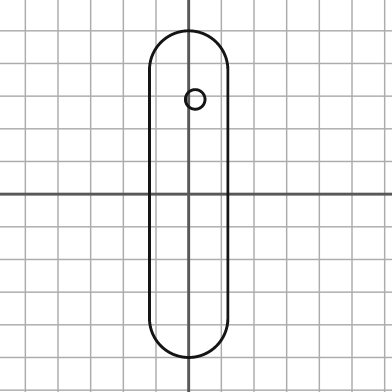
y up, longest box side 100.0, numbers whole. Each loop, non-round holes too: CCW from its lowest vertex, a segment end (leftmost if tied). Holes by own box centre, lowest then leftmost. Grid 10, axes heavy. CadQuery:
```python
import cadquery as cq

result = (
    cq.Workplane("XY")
    .moveTo(-12.0, -38.0)
    .threePointArc((0.0, -50.0), (12.0, -38.0))
    .lineTo(12.0, 38.0)
    .threePointArc((0.0, 50.0), (-12.0, 38.0))
    .close()
    .moveTo(2.0, 29.0)
    .circle(3.0)
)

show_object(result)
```